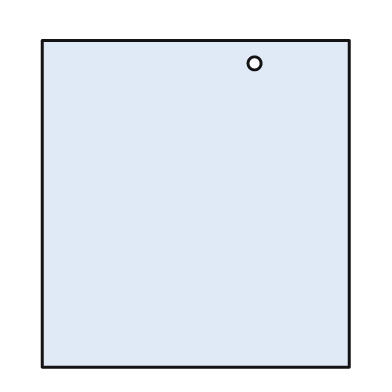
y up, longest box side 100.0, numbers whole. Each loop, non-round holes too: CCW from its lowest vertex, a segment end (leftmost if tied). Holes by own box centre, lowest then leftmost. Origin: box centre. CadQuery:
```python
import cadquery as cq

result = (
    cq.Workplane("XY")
    .moveTo(-47.0, -50.0)
    .lineTo(47.0, -50.0)
    .lineTo(47.0, 50.0)
    .lineTo(-47.0, 50.0)
    .close()
    .moveTo(18.0, 43.0)
    .circle(2.0)
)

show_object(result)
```